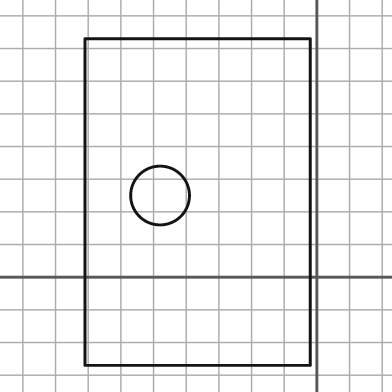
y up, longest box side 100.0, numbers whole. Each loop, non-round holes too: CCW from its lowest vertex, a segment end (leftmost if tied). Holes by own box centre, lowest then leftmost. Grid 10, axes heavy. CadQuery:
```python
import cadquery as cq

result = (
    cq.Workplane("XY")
    .moveTo(-71.0, -27.0)
    .lineTo(-2.0, -27.0)
    .lineTo(-2.0, 73.0)
    .lineTo(-71.0, 73.0)
    .close()
    .moveTo(-48.0, 25.0)
    .circle(9.0)
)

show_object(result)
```